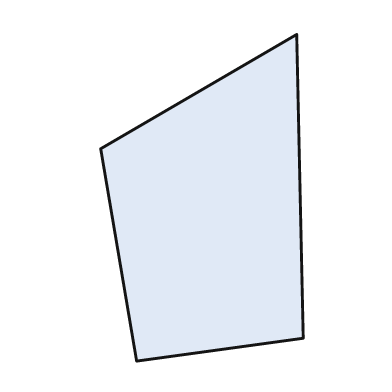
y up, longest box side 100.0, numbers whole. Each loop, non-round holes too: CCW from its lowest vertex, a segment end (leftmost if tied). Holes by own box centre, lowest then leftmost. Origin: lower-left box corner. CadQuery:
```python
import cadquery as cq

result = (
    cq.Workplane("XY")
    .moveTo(11.0, 0.0)
    .lineTo(62.0, 7.0)
    .lineTo(60.0, 100.0)
    .lineTo(0.0, 65.0)
    .close()
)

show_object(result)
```